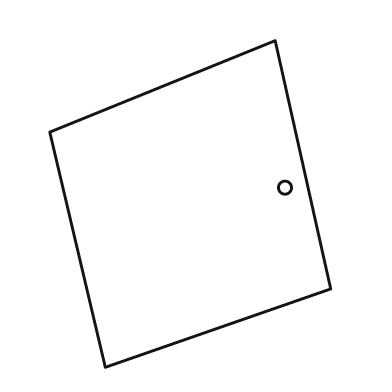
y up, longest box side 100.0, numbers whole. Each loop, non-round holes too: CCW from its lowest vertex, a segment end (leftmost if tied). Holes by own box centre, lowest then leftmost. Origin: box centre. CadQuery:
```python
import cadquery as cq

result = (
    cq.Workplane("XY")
    .moveTo(-26.0, -50.0)
    .lineTo(43.0, -26.0)
    .lineTo(26.0, 50.0)
    .lineTo(-43.0, 22.0)
    .close()
    .moveTo(29.0, 5.0)
    .circle(2.0)
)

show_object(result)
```